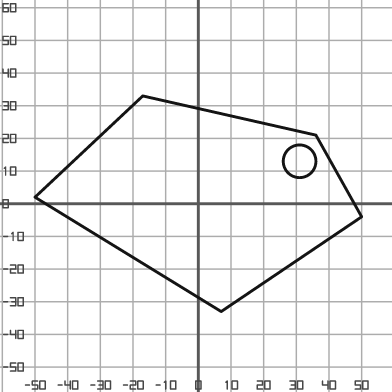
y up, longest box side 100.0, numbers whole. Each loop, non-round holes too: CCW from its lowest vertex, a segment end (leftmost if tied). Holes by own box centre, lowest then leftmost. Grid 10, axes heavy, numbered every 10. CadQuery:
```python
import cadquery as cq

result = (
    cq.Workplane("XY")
    .moveTo(7.0, -33.0)
    .lineTo(50.0, -4.0)
    .lineTo(36.0, 21.0)
    .lineTo(-17.0, 33.0)
    .lineTo(-50.0, 2.0)
    .close()
    .moveTo(31.0, 13.0)
    .circle(5.0)
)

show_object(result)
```